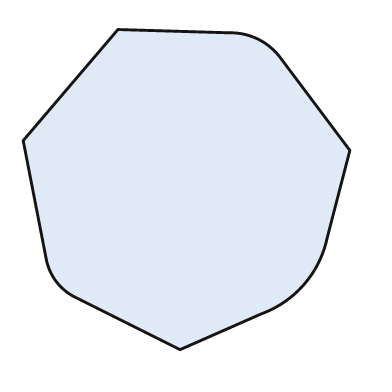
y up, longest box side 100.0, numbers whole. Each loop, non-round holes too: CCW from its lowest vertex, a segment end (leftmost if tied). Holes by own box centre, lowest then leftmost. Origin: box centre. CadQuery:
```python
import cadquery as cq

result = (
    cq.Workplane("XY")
    .moveTo(-2.0, -49.0)
    .lineTo(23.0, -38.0)
    .threePointArc((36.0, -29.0), (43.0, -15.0))
    .lineTo(50.0, 12.0)
    .lineTo(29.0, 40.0)
    .threePointArc((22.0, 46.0), (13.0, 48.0))
    .lineTo(-21.0, 49.0)
    .lineTo(-50.0, 15.0)
    .lineTo(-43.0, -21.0)
    .threePointArc((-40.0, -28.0), (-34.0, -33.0))
    .close()
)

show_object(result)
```